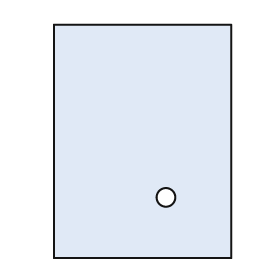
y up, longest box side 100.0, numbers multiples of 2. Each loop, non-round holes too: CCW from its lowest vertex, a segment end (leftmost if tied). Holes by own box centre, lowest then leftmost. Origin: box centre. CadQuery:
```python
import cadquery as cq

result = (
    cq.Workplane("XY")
    .moveTo(-38.0, -50.0)
    .lineTo(38.0, -50.0)
    .lineTo(38.0, 50.0)
    .lineTo(-38.0, 50.0)
    .close()
    .moveTo(10.0, -24.0)
    .circle(4.0)
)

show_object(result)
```